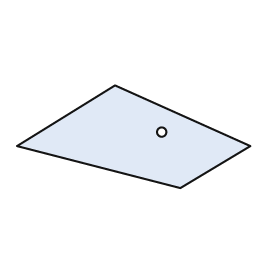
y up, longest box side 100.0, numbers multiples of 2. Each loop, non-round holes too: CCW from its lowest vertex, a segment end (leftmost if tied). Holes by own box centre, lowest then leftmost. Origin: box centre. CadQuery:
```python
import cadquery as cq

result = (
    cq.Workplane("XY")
    .moveTo(20.0, -22.0)
    .lineTo(50.0, -4.0)
    .lineTo(-8.0, 22.0)
    .lineTo(-50.0, -4.0)
    .close()
    .moveTo(12.0, 2.0)
    .circle(2.0)
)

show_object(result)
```